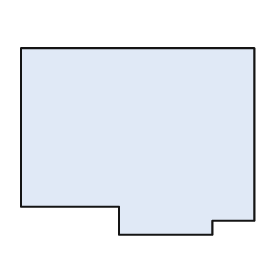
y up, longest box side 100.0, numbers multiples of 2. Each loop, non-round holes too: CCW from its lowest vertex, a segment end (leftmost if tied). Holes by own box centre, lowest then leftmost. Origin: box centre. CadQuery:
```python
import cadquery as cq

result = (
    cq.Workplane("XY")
    .moveTo(-8.0, -40.0)
    .lineTo(32.0, -40.0)
    .lineTo(32.0, -34.0)
    .lineTo(50.0, -34.0)
    .lineTo(50.0, 40.0)
    .lineTo(-50.0, 40.0)
    .lineTo(-50.0, -28.0)
    .lineTo(-8.0, -28.0)
    .close()
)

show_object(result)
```